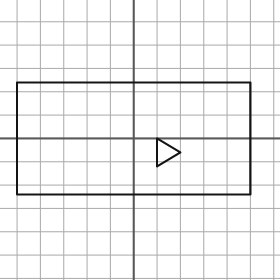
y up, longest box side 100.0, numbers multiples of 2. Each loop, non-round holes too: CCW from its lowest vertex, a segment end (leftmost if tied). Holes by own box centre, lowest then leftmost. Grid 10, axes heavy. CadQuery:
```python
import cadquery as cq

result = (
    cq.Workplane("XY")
    .moveTo(-50.0, -24.0)
    .lineTo(50.0, -24.0)
    .lineTo(50.0, 24.0)
    .lineTo(-50.0, 24.0)
    .close()
    .moveTo(10.0, -12.0)
    .lineTo(20.0, -6.0)
    .lineTo(10.0, 0.0)
    .close()
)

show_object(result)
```